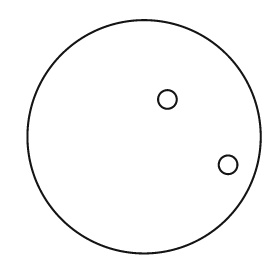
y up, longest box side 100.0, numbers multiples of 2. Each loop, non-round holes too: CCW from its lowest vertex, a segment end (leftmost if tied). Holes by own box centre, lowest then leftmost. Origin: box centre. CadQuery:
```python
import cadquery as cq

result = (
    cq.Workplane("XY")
    .moveTo(0.0, 0.0)
    .circle(50.0)
    .moveTo(36.0, -12.0)
    .circle(4.0)
    .moveTo(10.0, 16.0)
    .circle(4.0)
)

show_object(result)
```